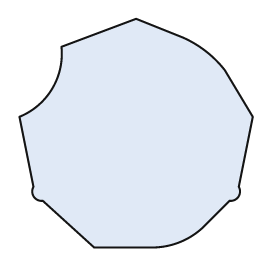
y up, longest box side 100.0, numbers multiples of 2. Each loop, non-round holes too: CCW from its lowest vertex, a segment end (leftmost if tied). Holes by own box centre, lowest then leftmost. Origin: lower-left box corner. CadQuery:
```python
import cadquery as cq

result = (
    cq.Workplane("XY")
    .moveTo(32.0, 0.0)
    .lineTo(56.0, 0.0)
    .threePointArc((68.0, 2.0), (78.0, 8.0))
    .lineTo(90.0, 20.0)
    .threePointArc((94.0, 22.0), (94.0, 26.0))
    .lineTo(100.0, 56.0)
    .lineTo(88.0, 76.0)
    .threePointArc((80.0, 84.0), (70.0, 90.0))
    .lineTo(50.0, 98.0)
    .lineTo(18.0, 86.0)
    .threePointArc((14.0, 68.0), (0.0, 56.0))
    .lineTo(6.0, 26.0)
    .threePointArc((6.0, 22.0), (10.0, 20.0))
    .close()
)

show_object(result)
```